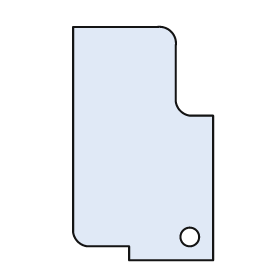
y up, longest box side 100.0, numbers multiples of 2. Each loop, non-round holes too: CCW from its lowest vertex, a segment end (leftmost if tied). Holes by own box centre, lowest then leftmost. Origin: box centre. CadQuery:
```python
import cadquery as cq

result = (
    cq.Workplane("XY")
    .moveTo(-6.0, -50.0)
    .lineTo(30.0, -50.0)
    .lineTo(30.0, 12.0)
    .lineTo(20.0, 12.0)
    .threePointArc((16.0, 14.0), (14.0, 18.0))
    .lineTo(14.0, 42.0)
    .threePointArc((12.0, 48.0), (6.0, 50.0))
    .lineTo(-30.0, 50.0)
    .lineTo(-30.0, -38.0)
    .threePointArc((-28.0, -42.0), (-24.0, -44.0))
    .lineTo(-6.0, -44.0)
    .close()
    .moveTo(20.0, -40.0)
    .circle(4.0)
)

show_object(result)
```